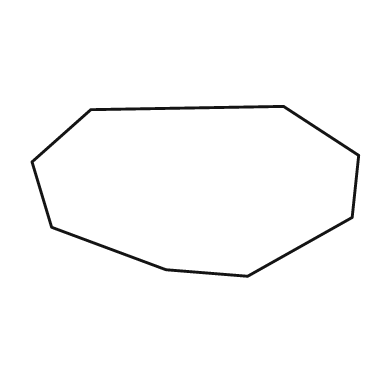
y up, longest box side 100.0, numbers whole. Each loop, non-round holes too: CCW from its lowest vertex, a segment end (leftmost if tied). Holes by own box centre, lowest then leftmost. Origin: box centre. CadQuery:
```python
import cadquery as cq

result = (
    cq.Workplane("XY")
    .moveTo(16.0, -26.0)
    .lineTo(48.0, -8.0)
    .lineTo(50.0, 11.0)
    .lineTo(27.0, 26.0)
    .lineTo(-32.0, 25.0)
    .lineTo(-50.0, 9.0)
    .lineTo(-44.0, -11.0)
    .lineTo(-9.0, -24.0)
    .close()
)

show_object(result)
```